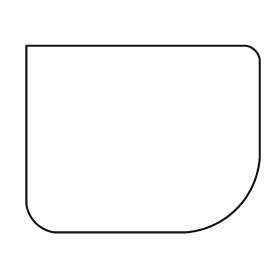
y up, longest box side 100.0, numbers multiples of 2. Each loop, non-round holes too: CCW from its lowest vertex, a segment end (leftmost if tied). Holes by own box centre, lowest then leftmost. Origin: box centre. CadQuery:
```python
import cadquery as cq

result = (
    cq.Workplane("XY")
    .moveTo(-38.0, -40.0)
    .lineTo(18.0, -40.0)
    .threePointArc((40.0, -30.0), (50.0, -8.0))
    .lineTo(50.0, 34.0)
    .threePointArc((48.0, 38.0), (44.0, 40.0))
    .lineTo(-50.0, 40.0)
    .lineTo(-50.0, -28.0)
    .threePointArc((-46.0, -36.0), (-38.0, -40.0))
    .close()
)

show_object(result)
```